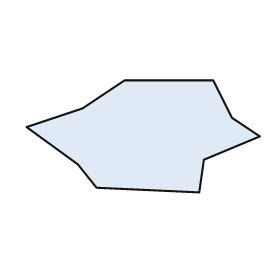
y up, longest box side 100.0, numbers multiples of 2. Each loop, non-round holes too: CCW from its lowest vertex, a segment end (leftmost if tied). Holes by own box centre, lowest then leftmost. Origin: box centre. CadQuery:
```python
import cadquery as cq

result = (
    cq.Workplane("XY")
    .moveTo(24.0, -24.0)
    .lineTo(26.0, -10.0)
    .lineTo(50.0, 0.0)
    .lineTo(38.0, 8.0)
    .lineTo(30.0, 24.0)
    .lineTo(-8.0, 24.0)
    .lineTo(-26.0, 12.0)
    .lineTo(-50.0, 4.0)
    .lineTo(-28.0, -12.0)
    .lineTo(-20.0, -22.0)
    .close()
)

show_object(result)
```